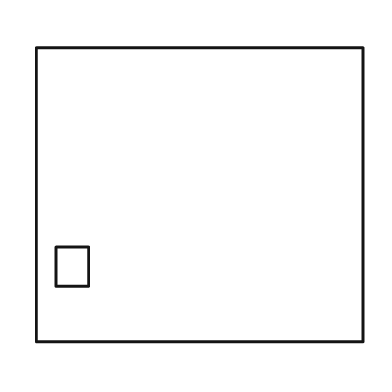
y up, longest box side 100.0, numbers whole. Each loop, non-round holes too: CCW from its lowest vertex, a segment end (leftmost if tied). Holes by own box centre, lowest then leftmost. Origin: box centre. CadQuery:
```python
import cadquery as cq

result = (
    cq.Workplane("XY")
    .moveTo(-50.0, -45.0)
    .lineTo(50.0, -45.0)
    .lineTo(50.0, 45.0)
    .lineTo(-50.0, 45.0)
    .close()
    .moveTo(-44.0, -28.0)
    .lineTo(-34.0, -28.0)
    .lineTo(-34.0, -16.0)
    .lineTo(-44.0, -16.0)
    .close()
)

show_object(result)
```